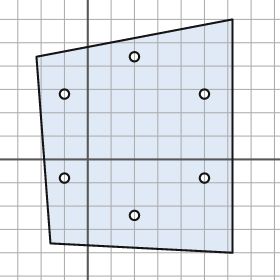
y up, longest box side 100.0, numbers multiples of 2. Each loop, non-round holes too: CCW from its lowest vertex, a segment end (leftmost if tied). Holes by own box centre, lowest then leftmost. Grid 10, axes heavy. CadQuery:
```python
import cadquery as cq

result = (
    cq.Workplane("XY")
    .moveTo(62.0, -40.0)
    .lineTo(62.0, 60.0)
    .lineTo(-22.0, 44.0)
    .lineTo(-16.0, -36.0)
    .close()
    .moveTo(20.0, -24.0)
    .circle(2.0)
    .moveTo(-10.0, -8.0)
    .circle(2.0)
    .moveTo(50.0, -8.0)
    .circle(2.0)
    .moveTo(-10.0, 28.0)
    .circle(2.0)
    .moveTo(50.0, 28.0)
    .circle(2.0)
    .moveTo(20.0, 44.0)
    .circle(2.0)
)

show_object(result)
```